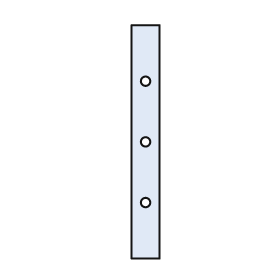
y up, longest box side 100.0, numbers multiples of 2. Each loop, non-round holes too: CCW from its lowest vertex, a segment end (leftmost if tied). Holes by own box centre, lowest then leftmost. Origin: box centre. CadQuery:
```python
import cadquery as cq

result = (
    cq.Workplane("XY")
    .moveTo(-6.0, -50.0)
    .lineTo(6.0, -50.0)
    .lineTo(6.0, 50.0)
    .lineTo(-6.0, 50.0)
    .close()
    .moveTo(0.0, -26.0)
    .circle(2.0)
    .moveTo(0.0, 0.0)
    .circle(2.0)
    .moveTo(0.0, 26.0)
    .circle(2.0)
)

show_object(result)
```